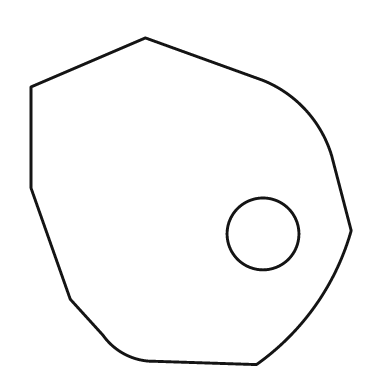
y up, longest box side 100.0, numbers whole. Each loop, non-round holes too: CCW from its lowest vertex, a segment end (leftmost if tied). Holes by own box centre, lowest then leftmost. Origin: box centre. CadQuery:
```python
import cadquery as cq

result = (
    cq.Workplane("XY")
    .moveTo(20.0, -50.0)
    .threePointArc((38.0, -32.0), (49.0, -9.0))
    .lineTo(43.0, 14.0)
    .threePointArc((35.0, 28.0), (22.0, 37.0))
    .lineTo(-14.0, 50.0)
    .lineTo(-49.0, 35.0)
    .lineTo(-49.0, 4.0)
    .lineTo(-37.0, -30.0)
    .lineTo(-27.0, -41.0)
    .threePointArc((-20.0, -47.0), (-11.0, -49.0))
    .close()
    .moveTo(22.0, -10.0)
    .circle(11.0)
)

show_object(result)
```